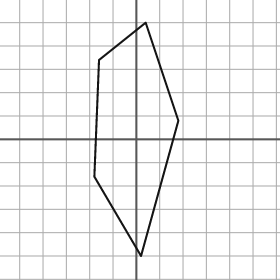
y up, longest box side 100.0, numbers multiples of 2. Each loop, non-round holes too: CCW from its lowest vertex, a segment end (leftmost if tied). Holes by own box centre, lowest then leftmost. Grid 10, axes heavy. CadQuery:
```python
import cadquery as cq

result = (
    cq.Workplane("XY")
    .moveTo(2.0, -50.0)
    .lineTo(18.0, 8.0)
    .lineTo(4.0, 50.0)
    .lineTo(-16.0, 34.0)
    .lineTo(-18.0, -16.0)
    .close()
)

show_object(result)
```